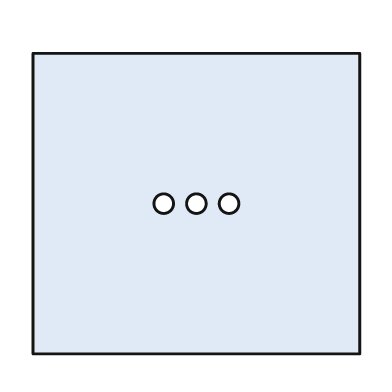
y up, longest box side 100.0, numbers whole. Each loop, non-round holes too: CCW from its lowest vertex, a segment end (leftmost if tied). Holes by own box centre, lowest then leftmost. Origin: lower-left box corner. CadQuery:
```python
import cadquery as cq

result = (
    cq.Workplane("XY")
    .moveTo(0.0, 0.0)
    .lineTo(100.0, 0.0)
    .lineTo(100.0, 92.0)
    .lineTo(0.0, 92.0)
    .close()
    .moveTo(40.0, 46.0)
    .circle(3.0)
    .moveTo(50.0, 46.0)
    .circle(3.0)
    .moveTo(60.0, 46.0)
    .circle(3.0)
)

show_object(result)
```